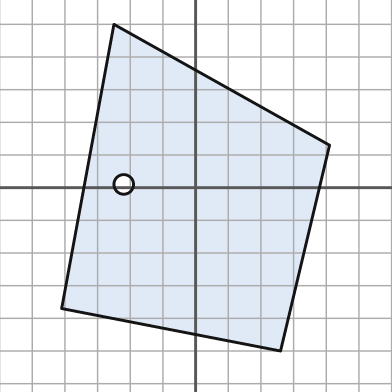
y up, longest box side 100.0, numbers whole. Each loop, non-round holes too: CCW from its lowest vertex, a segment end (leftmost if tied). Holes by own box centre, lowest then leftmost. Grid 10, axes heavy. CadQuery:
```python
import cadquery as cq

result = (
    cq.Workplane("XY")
    .moveTo(26.0, -50.0)
    .lineTo(41.0, 13.0)
    .lineTo(-25.0, 50.0)
    .lineTo(-41.0, -37.0)
    .close()
    .moveTo(-22.0, 1.0)
    .circle(3.0)
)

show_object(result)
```